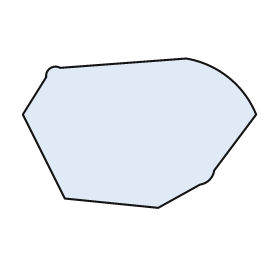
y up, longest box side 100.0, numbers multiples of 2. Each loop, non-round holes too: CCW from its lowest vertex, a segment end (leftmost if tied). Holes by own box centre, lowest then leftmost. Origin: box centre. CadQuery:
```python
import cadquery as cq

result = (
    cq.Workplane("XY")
    .moveTo(8.0, -32.0)
    .lineTo(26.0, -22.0)
    .threePointArc((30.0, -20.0), (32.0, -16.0))
    .lineTo(50.0, 8.0)
    .threePointArc((38.0, 24.0), (20.0, 32.0))
    .lineTo(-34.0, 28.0)
    .threePointArc((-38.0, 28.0), (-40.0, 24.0))
    .lineTo(-50.0, 8.0)
    .lineTo(-32.0, -28.0)
    .close()
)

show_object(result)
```